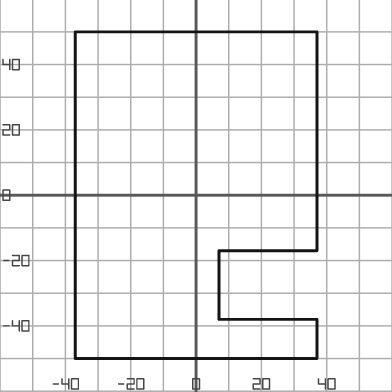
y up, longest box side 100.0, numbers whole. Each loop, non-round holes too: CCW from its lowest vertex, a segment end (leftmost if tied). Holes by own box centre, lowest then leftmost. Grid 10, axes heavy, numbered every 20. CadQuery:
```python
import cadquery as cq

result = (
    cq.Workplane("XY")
    .moveTo(-37.0, -50.0)
    .lineTo(37.0, -50.0)
    .lineTo(37.0, -38.0)
    .lineTo(7.0, -38.0)
    .lineTo(7.0, -17.0)
    .lineTo(37.0, -17.0)
    .lineTo(37.0, 50.0)
    .lineTo(-37.0, 50.0)
    .close()
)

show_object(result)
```